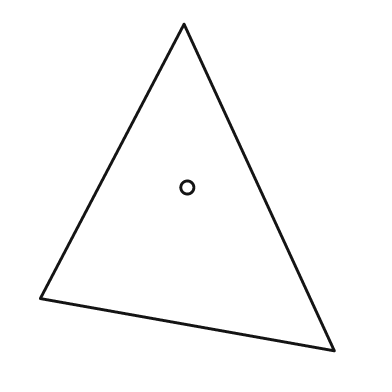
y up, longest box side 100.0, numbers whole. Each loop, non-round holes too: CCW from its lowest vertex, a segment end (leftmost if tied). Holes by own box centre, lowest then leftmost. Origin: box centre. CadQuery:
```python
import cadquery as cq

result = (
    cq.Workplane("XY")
    .moveTo(45.0, -50.0)
    .lineTo(-1.0, 50.0)
    .lineTo(-45.0, -34.0)
    .close()
    .moveTo(0.0, 0.0)
    .circle(2.0)
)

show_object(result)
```